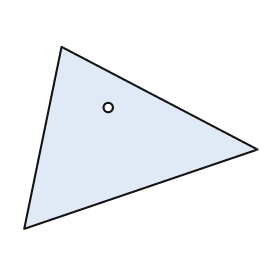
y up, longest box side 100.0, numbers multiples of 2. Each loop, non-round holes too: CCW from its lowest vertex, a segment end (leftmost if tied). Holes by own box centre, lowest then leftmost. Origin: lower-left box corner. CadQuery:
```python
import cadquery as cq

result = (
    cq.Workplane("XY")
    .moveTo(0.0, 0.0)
    .lineTo(100.0, 34.0)
    .lineTo(16.0, 78.0)
    .close()
    .moveTo(36.0, 52.0)
    .circle(2.0)
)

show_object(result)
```